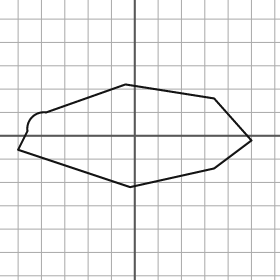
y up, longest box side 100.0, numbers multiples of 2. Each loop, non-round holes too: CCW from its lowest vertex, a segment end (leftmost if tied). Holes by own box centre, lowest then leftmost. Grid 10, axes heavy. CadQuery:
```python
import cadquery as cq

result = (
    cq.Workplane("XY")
    .moveTo(-2.0, -22.0)
    .lineTo(34.0, -14.0)
    .lineTo(50.0, -2.0)
    .lineTo(34.0, 16.0)
    .lineTo(-4.0, 22.0)
    .lineTo(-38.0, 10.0)
    .threePointArc((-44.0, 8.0), (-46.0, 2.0))
    .lineTo(-50.0, -6.0)
    .close()
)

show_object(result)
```